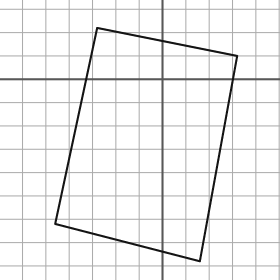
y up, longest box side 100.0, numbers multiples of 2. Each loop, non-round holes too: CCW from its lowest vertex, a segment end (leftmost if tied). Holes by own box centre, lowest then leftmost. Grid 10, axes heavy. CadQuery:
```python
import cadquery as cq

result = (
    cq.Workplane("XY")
    .moveTo(16.0, -78.0)
    .lineTo(32.0, 10.0)
    .lineTo(-28.0, 22.0)
    .lineTo(-46.0, -62.0)
    .close()
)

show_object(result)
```